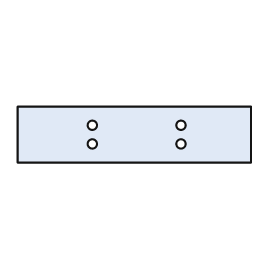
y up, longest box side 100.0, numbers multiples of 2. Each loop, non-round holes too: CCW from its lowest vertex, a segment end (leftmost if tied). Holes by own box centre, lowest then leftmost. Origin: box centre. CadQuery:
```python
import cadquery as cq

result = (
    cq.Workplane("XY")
    .moveTo(-50.0, -12.0)
    .lineTo(50.0, -12.0)
    .lineTo(50.0, 12.0)
    .lineTo(-50.0, 12.0)
    .close()
    .moveTo(-18.0, -4.0)
    .circle(2.0)
    .moveTo(20.0, -4.0)
    .circle(2.0)
    .moveTo(-18.0, 4.0)
    .circle(2.0)
    .moveTo(20.0, 4.0)
    .circle(2.0)
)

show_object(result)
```